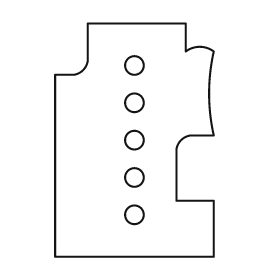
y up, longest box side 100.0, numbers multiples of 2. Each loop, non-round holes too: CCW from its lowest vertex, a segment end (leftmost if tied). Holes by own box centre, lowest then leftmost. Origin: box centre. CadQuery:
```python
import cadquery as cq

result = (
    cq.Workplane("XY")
    .moveTo(-34.0, -50.0)
    .lineTo(34.0, -50.0)
    .lineTo(34.0, -26.0)
    .lineTo(18.0, -26.0)
    .lineTo(18.0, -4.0)
    .threePointArc((20.0, 0.0), (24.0, 2.0))
    .lineTo(34.0, 2.0)
    .threePointArc((32.0, 20.0), (34.0, 38.0))
    .threePointArc((28.0, 40.0), (22.0, 38.0))
    .lineTo(22.0, 50.0)
    .lineTo(-20.0, 50.0)
    .lineTo(-20.0, 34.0)
    .threePointArc((-22.0, 30.0), (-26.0, 28.0))
    .lineTo(-34.0, 28.0)
    .close()
    .moveTo(0.0, -32.0)
    .circle(4.0)
    .moveTo(0.0, -16.0)
    .circle(4.0)
    .moveTo(0.0, 0.0)
    .circle(4.0)
    .moveTo(0.0, 16.0)
    .circle(4.0)
    .moveTo(0.0, 32.0)
    .circle(4.0)
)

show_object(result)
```